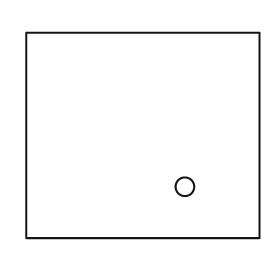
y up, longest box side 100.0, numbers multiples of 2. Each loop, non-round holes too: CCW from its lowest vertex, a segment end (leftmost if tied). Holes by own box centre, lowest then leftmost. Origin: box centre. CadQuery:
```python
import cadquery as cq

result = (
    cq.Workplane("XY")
    .moveTo(-50.0, -44.0)
    .lineTo(50.0, -44.0)
    .lineTo(50.0, 44.0)
    .lineTo(-50.0, 44.0)
    .close()
    .moveTo(18.0, -22.0)
    .circle(4.0)
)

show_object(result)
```